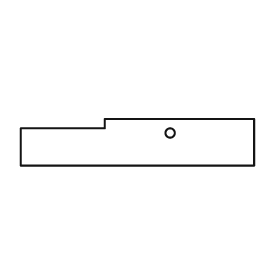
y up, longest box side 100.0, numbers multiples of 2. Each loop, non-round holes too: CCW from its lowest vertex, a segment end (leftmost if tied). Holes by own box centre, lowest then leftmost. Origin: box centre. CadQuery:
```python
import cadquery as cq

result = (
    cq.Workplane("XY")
    .moveTo(-50.0, -10.0)
    .lineTo(50.0, -10.0)
    .lineTo(50.0, 10.0)
    .lineTo(-14.0, 10.0)
    .lineTo(-14.0, 6.0)
    .lineTo(-50.0, 6.0)
    .close()
    .moveTo(14.0, 4.0)
    .circle(2.0)
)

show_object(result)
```